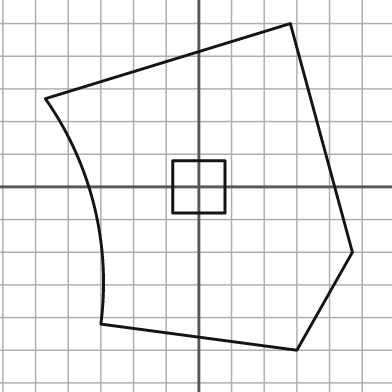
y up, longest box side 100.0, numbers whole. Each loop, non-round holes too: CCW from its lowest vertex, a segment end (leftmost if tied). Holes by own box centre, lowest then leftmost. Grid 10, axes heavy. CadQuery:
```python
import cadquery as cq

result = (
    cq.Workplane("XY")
    .moveTo(30.0, -50.0)
    .lineTo(47.0, -20.0)
    .lineTo(28.0, 50.0)
    .lineTo(-47.0, 27.0)
    .threePointArc((-32.0, -6.0), (-30.0, -42.0))
    .close()
    .moveTo(-8.0, -8.0)
    .lineTo(8.0, -8.0)
    .lineTo(8.0, 8.0)
    .lineTo(-8.0, 8.0)
    .close()
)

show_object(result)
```